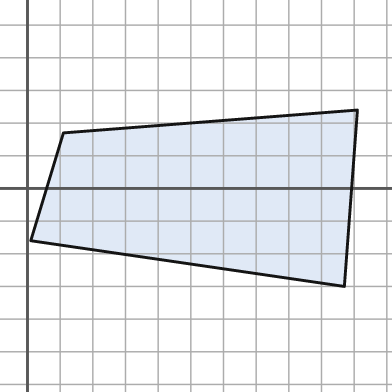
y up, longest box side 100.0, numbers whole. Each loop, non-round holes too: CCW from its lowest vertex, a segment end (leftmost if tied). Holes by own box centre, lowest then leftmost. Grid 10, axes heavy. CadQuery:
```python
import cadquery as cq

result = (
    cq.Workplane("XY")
    .moveTo(97.0, -30.0)
    .lineTo(101.0, 24.0)
    .lineTo(11.0, 17.0)
    .lineTo(1.0, -16.0)
    .close()
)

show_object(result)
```